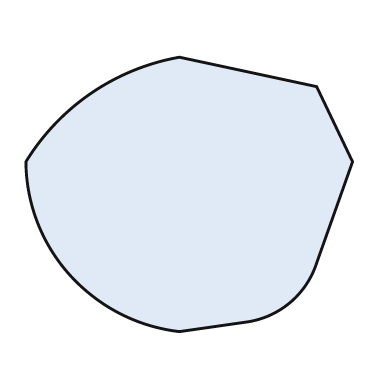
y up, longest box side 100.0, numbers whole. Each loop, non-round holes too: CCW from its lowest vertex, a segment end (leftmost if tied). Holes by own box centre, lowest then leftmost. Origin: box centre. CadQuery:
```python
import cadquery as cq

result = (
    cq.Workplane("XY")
    .moveTo(-3.0, -42.0)
    .lineTo(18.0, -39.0)
    .threePointArc((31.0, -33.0), (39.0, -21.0))
    .lineTo(50.0, 10.0)
    .lineTo(39.0, 33.0)
    .lineTo(-3.0, 42.0)
    .threePointArc((-30.0, 31.0), (-50.0, 10.0))
    .threePointArc((-45.0, -12.0), (-31.0, -30.0))
    .threePointArc((-18.0, -38.0), (-3.0, -42.0))
    .close()
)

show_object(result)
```